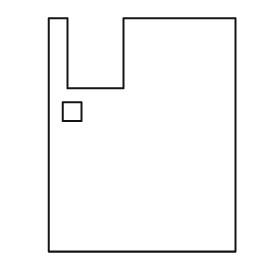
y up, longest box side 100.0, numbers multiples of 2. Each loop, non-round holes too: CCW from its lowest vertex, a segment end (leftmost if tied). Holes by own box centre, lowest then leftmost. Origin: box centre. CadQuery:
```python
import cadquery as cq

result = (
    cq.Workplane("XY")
    .moveTo(-40.0, -50.0)
    .lineTo(40.0, -50.0)
    .lineTo(40.0, 50.0)
    .lineTo(-8.0, 50.0)
    .lineTo(-8.0, 20.0)
    .lineTo(-32.0, 20.0)
    .lineTo(-32.0, 50.0)
    .lineTo(-40.0, 50.0)
    .close()
    .moveTo(-34.0, 6.0)
    .lineTo(-26.0, 6.0)
    .lineTo(-26.0, 14.0)
    .lineTo(-34.0, 14.0)
    .close()
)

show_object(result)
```